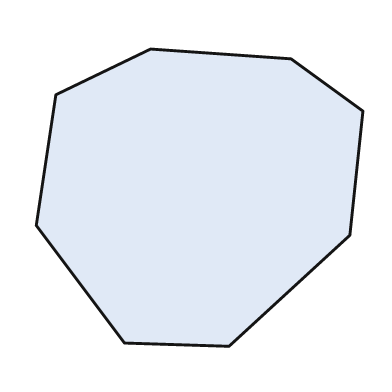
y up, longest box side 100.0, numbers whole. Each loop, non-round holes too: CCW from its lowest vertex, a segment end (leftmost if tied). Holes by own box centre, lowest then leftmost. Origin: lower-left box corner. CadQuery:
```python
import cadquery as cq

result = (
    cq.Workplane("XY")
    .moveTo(59.0, 0.0)
    .lineTo(96.0, 34.0)
    .lineTo(100.0, 72.0)
    .lineTo(78.0, 88.0)
    .lineTo(35.0, 91.0)
    .lineTo(6.0, 77.0)
    .lineTo(0.0, 37.0)
    .lineTo(27.0, 1.0)
    .close()
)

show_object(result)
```